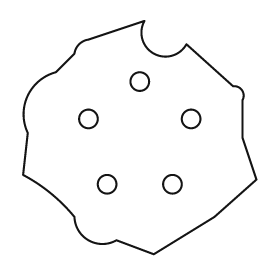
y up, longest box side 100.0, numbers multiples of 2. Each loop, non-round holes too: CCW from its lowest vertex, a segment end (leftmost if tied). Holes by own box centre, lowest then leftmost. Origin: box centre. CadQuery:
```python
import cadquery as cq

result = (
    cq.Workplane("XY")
    .moveTo(6.0, -50.0)
    .lineTo(32.0, -34.0)
    .lineTo(50.0, -18.0)
    .lineTo(44.0, 0.0)
    .lineTo(44.0, 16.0)
    .threePointArc((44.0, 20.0), (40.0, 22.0))
    .lineTo(20.0, 40.0)
    .threePointArc((6.0, 36.0), (2.0, 50.0))
    .lineTo(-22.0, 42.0)
    .threePointArc((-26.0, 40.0), (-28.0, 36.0))
    .lineTo(-36.0, 28.0)
    .threePointArc((-48.0, 18.0), (-48.0, 2.0))
    .lineTo(-50.0, -16.0)
    .threePointArc((-38.0, -24.0), (-28.0, -34.0))
    .threePointArc((-22.0, -44.0), (-10.0, -44.0))
    .close()
    .moveTo(-14.0, -20.0)
    .circle(4.0)
    .moveTo(14.0, -20.0)
    .circle(4.0)
    .moveTo(-22.0, 8.0)
    .circle(4.0)
    .moveTo(22.0, 8.0)
    .circle(4.0)
    .moveTo(0.0, 24.0)
    .circle(4.0)
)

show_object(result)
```